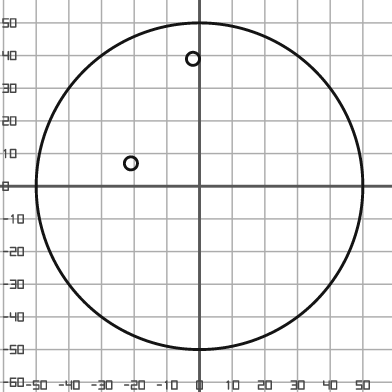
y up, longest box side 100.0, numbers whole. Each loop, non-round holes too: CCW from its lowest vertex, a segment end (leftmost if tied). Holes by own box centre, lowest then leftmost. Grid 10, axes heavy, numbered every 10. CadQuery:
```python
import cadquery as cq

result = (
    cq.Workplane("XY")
    .moveTo(0.0, 0.0)
    .circle(50.0)
    .moveTo(-21.0, 7.0)
    .circle(2.0)
    .moveTo(-2.0, 39.0)
    .circle(2.0)
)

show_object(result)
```